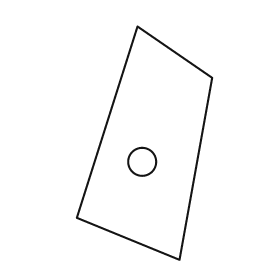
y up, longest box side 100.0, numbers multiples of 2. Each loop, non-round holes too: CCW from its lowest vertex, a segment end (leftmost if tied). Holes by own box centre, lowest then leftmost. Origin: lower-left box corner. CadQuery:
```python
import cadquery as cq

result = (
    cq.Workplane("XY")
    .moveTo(44.0, 0.0)
    .lineTo(58.0, 78.0)
    .lineTo(26.0, 100.0)
    .lineTo(0.0, 18.0)
    .close()
    .moveTo(28.0, 42.0)
    .circle(6.0)
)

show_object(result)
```